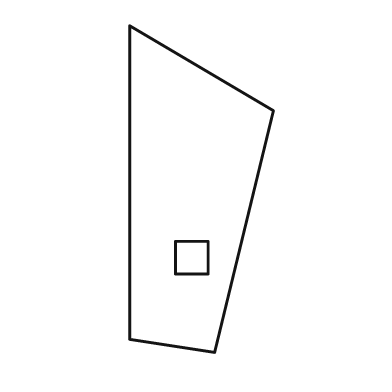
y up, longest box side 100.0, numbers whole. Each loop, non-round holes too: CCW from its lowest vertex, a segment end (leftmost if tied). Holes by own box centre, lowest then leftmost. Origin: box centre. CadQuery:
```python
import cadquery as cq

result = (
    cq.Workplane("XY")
    .moveTo(4.0, -50.0)
    .lineTo(22.0, 24.0)
    .lineTo(-22.0, 50.0)
    .lineTo(-22.0, -46.0)
    .close()
    .moveTo(-8.0, -26.0)
    .lineTo(2.0, -26.0)
    .lineTo(2.0, -16.0)
    .lineTo(-8.0, -16.0)
    .close()
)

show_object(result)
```